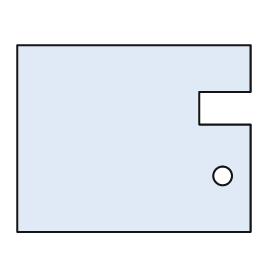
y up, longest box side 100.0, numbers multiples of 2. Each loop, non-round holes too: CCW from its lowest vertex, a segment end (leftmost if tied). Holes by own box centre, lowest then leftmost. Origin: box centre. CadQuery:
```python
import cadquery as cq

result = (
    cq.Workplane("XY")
    .moveTo(-50.0, -40.0)
    .lineTo(50.0, -40.0)
    .lineTo(50.0, 6.0)
    .lineTo(28.0, 6.0)
    .lineTo(28.0, 20.0)
    .lineTo(50.0, 20.0)
    .lineTo(50.0, 40.0)
    .lineTo(-50.0, 40.0)
    .close()
    .moveTo(38.0, -16.0)
    .circle(4.0)
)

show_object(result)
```